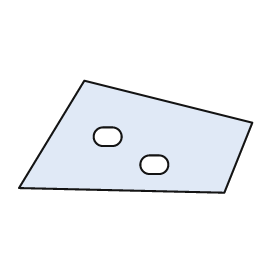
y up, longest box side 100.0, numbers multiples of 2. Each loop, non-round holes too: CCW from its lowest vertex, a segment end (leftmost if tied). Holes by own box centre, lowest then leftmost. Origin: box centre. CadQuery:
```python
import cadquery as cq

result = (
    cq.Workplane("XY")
    .moveTo(38.0, -24.0)
    .lineTo(50.0, 6.0)
    .lineTo(-22.0, 24.0)
    .lineTo(-50.0, -22.0)
    .close()
    .moveTo(6.0, -16.0)
    .lineTo(10.0, -16.0)
    .threePointArc((14.0, -12.0), (10.0, -8.0))
    .lineTo(6.0, -8.0)
    .threePointArc((2.0, -12.0), (6.0, -16.0))
    .close()
    .moveTo(-14.0, -4.0)
    .lineTo(-10.0, -4.0)
    .threePointArc((-6.0, 0.0), (-10.0, 4.0))
    .lineTo(-14.0, 4.0)
    .threePointArc((-18.0, 0.0), (-14.0, -4.0))
    .close()
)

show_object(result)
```